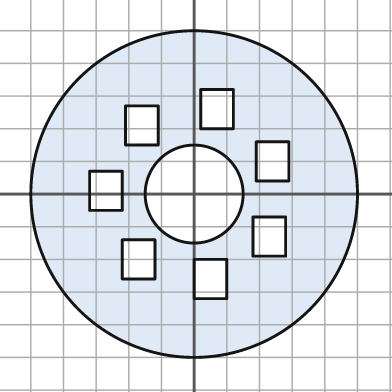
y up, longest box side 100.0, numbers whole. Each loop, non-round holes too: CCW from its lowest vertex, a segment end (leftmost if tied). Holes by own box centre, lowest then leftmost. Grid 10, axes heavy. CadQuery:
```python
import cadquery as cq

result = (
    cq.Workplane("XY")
    .moveTo(0.0, 0.0)
    .circle(50.0)
    .moveTo(0.0, -32.0)
    .lineTo(10.0, -32.0)
    .lineTo(10.0, -20.0)
    .lineTo(0.0, -20.0)
    .close()
    .moveTo(-22.0, -26.0)
    .lineTo(-12.0, -26.0)
    .lineTo(-12.0, -14.0)
    .lineTo(-22.0, -14.0)
    .close()
    .moveTo(18.0, -19.0)
    .lineTo(28.0, -19.0)
    .lineTo(28.0, -7.0)
    .lineTo(18.0, -7.0)
    .close()
    .moveTo(0.0, 0.0)
    .circle(15.0)
    .moveTo(-32.0, -5.0)
    .lineTo(-22.0, -5.0)
    .lineTo(-22.0, 7.0)
    .lineTo(-32.0, 7.0)
    .close()
    .moveTo(19.0, 4.0)
    .lineTo(29.0, 4.0)
    .lineTo(29.0, 16.0)
    .lineTo(19.0, 16.0)
    .close()
    .moveTo(-21.0, 15.0)
    .lineTo(-11.0, 15.0)
    .lineTo(-11.0, 27.0)
    .lineTo(-21.0, 27.0)
    .close()
    .moveTo(2.0, 20.0)
    .lineTo(12.0, 20.0)
    .lineTo(12.0, 32.0)
    .lineTo(2.0, 32.0)
    .close()
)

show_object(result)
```